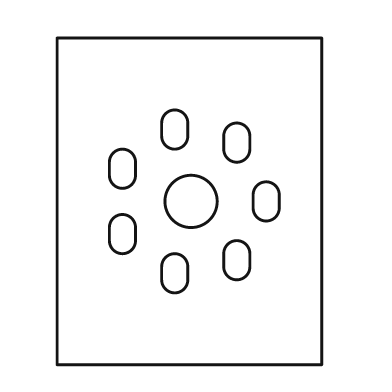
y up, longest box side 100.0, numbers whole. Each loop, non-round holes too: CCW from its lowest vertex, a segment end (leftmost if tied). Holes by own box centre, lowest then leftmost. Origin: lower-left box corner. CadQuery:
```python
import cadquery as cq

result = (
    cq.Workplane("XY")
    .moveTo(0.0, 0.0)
    .lineTo(81.0, 0.0)
    .lineTo(81.0, 100.0)
    .lineTo(0.0, 100.0)
    .close()
    .moveTo(32.0, 26.0)
    .threePointArc((36.0, 22.0), (40.0, 26.0))
    .lineTo(40.0, 30.0)
    .threePointArc((36.0, 34.0), (32.0, 30.0))
    .close()
    .moveTo(51.0, 30.0)
    .threePointArc((55.0, 26.0), (59.0, 30.0))
    .lineTo(59.0, 34.0)
    .threePointArc((55.0, 38.0), (51.0, 34.0))
    .close()
    .moveTo(16.0, 38.0)
    .threePointArc((20.0, 34.0), (24.0, 38.0))
    .lineTo(24.0, 42.0)
    .threePointArc((20.0, 46.0), (16.0, 42.0))
    .close()
    .moveTo(41.0, 50.0)
    .circle(8.0)
    .moveTo(60.0, 48.0)
    .threePointArc((64.0, 44.0), (68.0, 48.0))
    .lineTo(68.0, 52.0)
    .threePointArc((64.0, 56.0), (60.0, 52.0))
    .close()
    .moveTo(16.0, 58.0)
    .threePointArc((20.0, 54.0), (24.0, 58.0))
    .lineTo(24.0, 62.0)
    .threePointArc((20.0, 66.0), (16.0, 62.0))
    .close()
    .moveTo(51.0, 66.0)
    .threePointArc((55.0, 62.0), (59.0, 66.0))
    .lineTo(59.0, 70.0)
    .threePointArc((55.0, 74.0), (51.0, 70.0))
    .close()
    .moveTo(32.0, 70.0)
    .threePointArc((36.0, 66.0), (40.0, 70.0))
    .lineTo(40.0, 74.0)
    .threePointArc((36.0, 78.0), (32.0, 74.0))
    .close()
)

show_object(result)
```